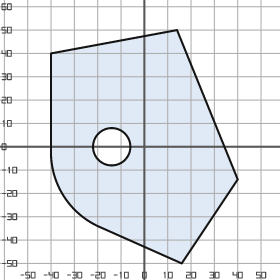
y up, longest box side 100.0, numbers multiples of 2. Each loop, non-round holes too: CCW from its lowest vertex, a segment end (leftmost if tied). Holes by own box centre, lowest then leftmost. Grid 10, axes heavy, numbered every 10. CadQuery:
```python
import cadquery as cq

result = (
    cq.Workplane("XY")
    .moveTo(16.0, -50.0)
    .lineTo(40.0, -14.0)
    .lineTo(14.0, 50.0)
    .lineTo(-40.0, 40.0)
    .lineTo(-40.0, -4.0)
    .threePointArc((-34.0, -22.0), (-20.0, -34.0))
    .close()
    .moveTo(-14.0, 0.0)
    .circle(8.0)
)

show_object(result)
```